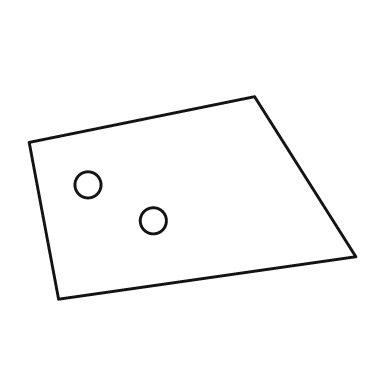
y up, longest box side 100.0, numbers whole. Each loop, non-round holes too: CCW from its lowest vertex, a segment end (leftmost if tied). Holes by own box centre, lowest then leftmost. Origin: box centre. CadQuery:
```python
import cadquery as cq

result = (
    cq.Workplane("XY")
    .moveTo(-41.0, -31.0)
    .lineTo(50.0, -18.0)
    .lineTo(19.0, 31.0)
    .lineTo(-50.0, 17.0)
    .close()
    .moveTo(-12.0, -7.0)
    .circle(4.0)
    .moveTo(-32.0, 4.0)
    .circle(4.0)
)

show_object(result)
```